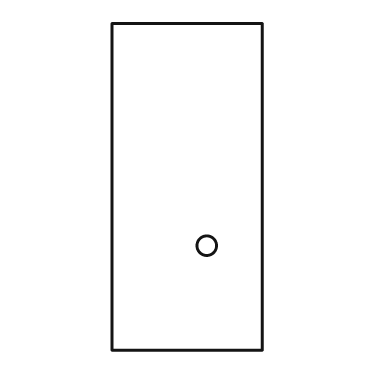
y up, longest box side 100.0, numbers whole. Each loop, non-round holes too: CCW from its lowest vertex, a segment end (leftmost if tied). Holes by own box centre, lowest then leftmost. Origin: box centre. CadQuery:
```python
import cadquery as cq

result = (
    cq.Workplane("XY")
    .moveTo(-23.0, -50.0)
    .lineTo(23.0, -50.0)
    .lineTo(23.0, 50.0)
    .lineTo(-23.0, 50.0)
    .close()
    .moveTo(6.0, -18.0)
    .circle(3.0)
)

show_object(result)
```